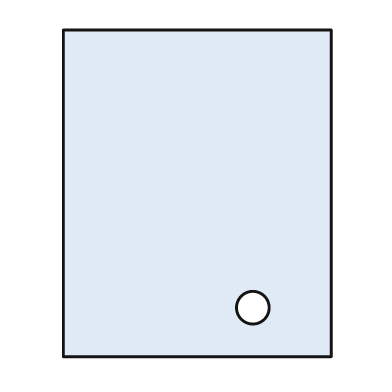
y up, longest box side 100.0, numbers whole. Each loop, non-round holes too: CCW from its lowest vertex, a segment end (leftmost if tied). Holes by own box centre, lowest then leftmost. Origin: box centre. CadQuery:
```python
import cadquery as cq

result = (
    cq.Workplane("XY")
    .moveTo(-41.0, -50.0)
    .lineTo(41.0, -50.0)
    .lineTo(41.0, 50.0)
    .lineTo(-41.0, 50.0)
    .close()
    .moveTo(17.0, -35.0)
    .circle(5.0)
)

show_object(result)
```